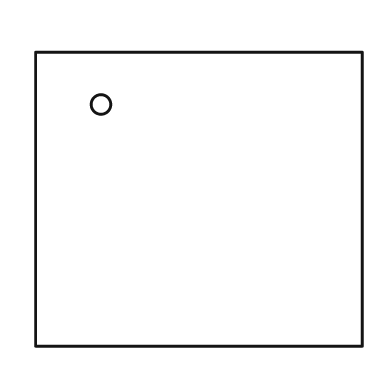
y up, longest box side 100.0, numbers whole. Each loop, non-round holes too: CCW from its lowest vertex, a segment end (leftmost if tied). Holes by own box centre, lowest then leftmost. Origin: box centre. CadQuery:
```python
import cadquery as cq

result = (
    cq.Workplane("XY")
    .moveTo(-50.0, -45.0)
    .lineTo(50.0, -45.0)
    .lineTo(50.0, 45.0)
    .lineTo(-50.0, 45.0)
    .close()
    .moveTo(-30.0, 29.0)
    .circle(3.0)
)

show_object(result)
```